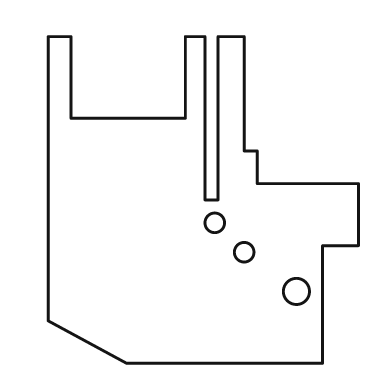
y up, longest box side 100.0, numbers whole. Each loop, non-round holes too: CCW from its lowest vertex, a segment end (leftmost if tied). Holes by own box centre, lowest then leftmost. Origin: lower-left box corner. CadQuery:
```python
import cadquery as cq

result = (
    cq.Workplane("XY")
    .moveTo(24.0, 0.0)
    .lineTo(84.0, 0.0)
    .lineTo(84.0, 36.0)
    .lineTo(95.0, 36.0)
    .lineTo(95.0, 55.0)
    .lineTo(64.0, 55.0)
    .lineTo(64.0, 65.0)
    .lineTo(60.0, 65.0)
    .lineTo(60.0, 100.0)
    .lineTo(52.0, 100.0)
    .lineTo(52.0, 50.0)
    .lineTo(48.0, 50.0)
    .lineTo(48.0, 100.0)
    .lineTo(42.0, 100.0)
    .lineTo(42.0, 75.0)
    .lineTo(7.0, 75.0)
    .lineTo(7.0, 100.0)
    .lineTo(0.0, 100.0)
    .lineTo(0.0, 13.0)
    .close()
    .moveTo(76.0, 22.0)
    .circle(4.0)
    .moveTo(60.0, 34.0)
    .circle(3.0)
    .moveTo(51.0, 43.0)
    .circle(3.0)
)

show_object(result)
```